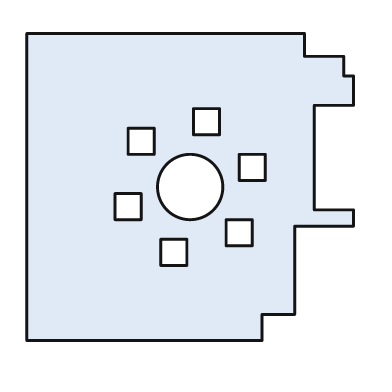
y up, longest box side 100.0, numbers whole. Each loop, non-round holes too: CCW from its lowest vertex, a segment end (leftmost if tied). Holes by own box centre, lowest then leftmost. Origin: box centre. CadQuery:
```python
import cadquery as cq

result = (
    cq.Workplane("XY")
    .moveTo(-50.0, -47.0)
    .lineTo(22.0, -47.0)
    .lineTo(22.0, -39.0)
    .lineTo(32.0, -39.0)
    .lineTo(32.0, -12.0)
    .lineTo(50.0, -12.0)
    .lineTo(50.0, -7.0)
    .lineTo(38.0, -7.0)
    .lineTo(38.0, 25.0)
    .lineTo(50.0, 25.0)
    .lineTo(50.0, 34.0)
    .lineTo(47.0, 34.0)
    .lineTo(47.0, 40.0)
    .lineTo(35.0, 40.0)
    .lineTo(35.0, 47.0)
    .lineTo(-50.0, 47.0)
    .close()
    .moveTo(-9.0, -24.0)
    .lineTo(-1.0, -24.0)
    .lineTo(-1.0, -16.0)
    .lineTo(-9.0, -16.0)
    .close()
    .moveTo(11.0, -18.0)
    .lineTo(19.0, -18.0)
    .lineTo(19.0, -10.0)
    .lineTo(11.0, -10.0)
    .close()
    .moveTo(-23.0, -10.0)
    .lineTo(-15.0, -10.0)
    .lineTo(-15.0, -2.0)
    .lineTo(-23.0, -2.0)
    .close()
    .moveTo(0.0, 0.0)
    .circle(10.0)
    .moveTo(15.0, 2.0)
    .lineTo(23.0, 2.0)
    .lineTo(23.0, 10.0)
    .lineTo(15.0, 10.0)
    .close()
    .moveTo(-19.0, 10.0)
    .lineTo(-11.0, 10.0)
    .lineTo(-11.0, 18.0)
    .lineTo(-19.0, 18.0)
    .close()
    .moveTo(1.0, 16.0)
    .lineTo(9.0, 16.0)
    .lineTo(9.0, 24.0)
    .lineTo(1.0, 24.0)
    .close()
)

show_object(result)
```